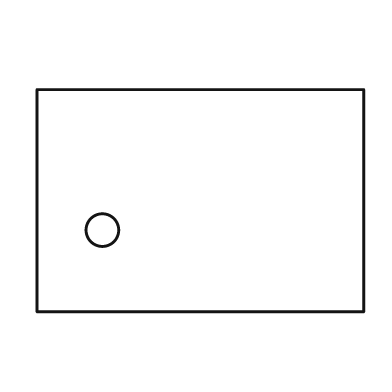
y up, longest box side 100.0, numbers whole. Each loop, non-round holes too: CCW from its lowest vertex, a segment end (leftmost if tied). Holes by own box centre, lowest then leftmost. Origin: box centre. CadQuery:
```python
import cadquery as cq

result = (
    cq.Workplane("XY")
    .moveTo(-50.0, -34.0)
    .lineTo(50.0, -34.0)
    .lineTo(50.0, 34.0)
    .lineTo(-50.0, 34.0)
    .close()
    .moveTo(-30.0, -9.0)
    .circle(5.0)
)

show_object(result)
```